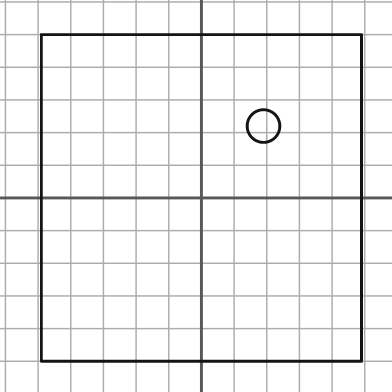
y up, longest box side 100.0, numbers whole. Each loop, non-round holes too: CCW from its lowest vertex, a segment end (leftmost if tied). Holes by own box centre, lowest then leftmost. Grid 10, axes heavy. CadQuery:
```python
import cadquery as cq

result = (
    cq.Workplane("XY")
    .moveTo(-49.0, -50.0)
    .lineTo(49.0, -50.0)
    .lineTo(49.0, 50.0)
    .lineTo(-49.0, 50.0)
    .close()
    .moveTo(19.0, 22.0)
    .circle(5.0)
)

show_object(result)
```